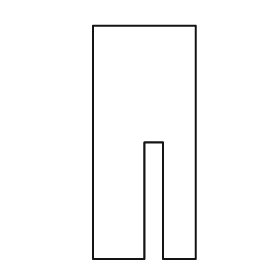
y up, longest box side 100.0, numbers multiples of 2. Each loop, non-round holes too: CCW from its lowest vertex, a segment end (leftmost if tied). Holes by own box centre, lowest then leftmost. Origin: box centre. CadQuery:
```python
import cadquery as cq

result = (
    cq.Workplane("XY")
    .moveTo(-22.0, -50.0)
    .lineTo(0.0, -50.0)
    .lineTo(0.0, 0.0)
    .lineTo(8.0, 0.0)
    .lineTo(8.0, -50.0)
    .lineTo(22.0, -50.0)
    .lineTo(22.0, 50.0)
    .lineTo(-22.0, 50.0)
    .close()
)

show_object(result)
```